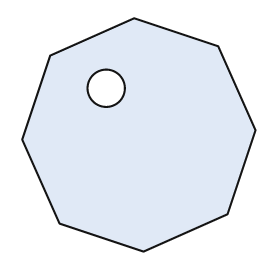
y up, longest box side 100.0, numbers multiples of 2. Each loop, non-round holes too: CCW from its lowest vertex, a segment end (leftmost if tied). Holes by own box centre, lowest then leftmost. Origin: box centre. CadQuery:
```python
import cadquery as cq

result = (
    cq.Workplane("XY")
    .moveTo(2.0, -50.0)
    .lineTo(38.0, -34.0)
    .lineTo(50.0, 2.0)
    .lineTo(34.0, 38.0)
    .lineTo(-2.0, 50.0)
    .lineTo(-38.0, 34.0)
    .lineTo(-50.0, -2.0)
    .lineTo(-34.0, -38.0)
    .close()
    .moveTo(-14.0, 20.0)
    .circle(8.0)
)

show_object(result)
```